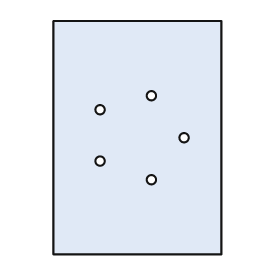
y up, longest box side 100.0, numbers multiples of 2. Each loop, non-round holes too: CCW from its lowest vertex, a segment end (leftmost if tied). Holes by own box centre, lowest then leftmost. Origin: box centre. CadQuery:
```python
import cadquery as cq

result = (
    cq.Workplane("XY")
    .moveTo(-36.0, -50.0)
    .lineTo(36.0, -50.0)
    .lineTo(36.0, 50.0)
    .lineTo(-36.0, 50.0)
    .close()
    .moveTo(6.0, -18.0)
    .circle(2.0)
    .moveTo(-16.0, -10.0)
    .circle(2.0)
    .moveTo(20.0, 0.0)
    .circle(2.0)
    .moveTo(-16.0, 12.0)
    .circle(2.0)
    .moveTo(6.0, 18.0)
    .circle(2.0)
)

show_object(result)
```